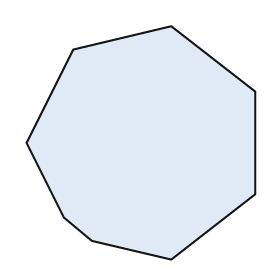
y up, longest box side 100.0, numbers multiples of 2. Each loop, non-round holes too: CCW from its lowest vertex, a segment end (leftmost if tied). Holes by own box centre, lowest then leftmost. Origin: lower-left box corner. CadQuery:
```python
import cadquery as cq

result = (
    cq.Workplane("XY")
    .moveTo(62.0, 0.0)
    .lineTo(98.0, 28.0)
    .lineTo(98.0, 72.0)
    .lineTo(62.0, 100.0)
    .lineTo(20.0, 90.0)
    .lineTo(0.0, 50.0)
    .lineTo(16.0, 18.0)
    .lineTo(28.0, 8.0)
    .close()
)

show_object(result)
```